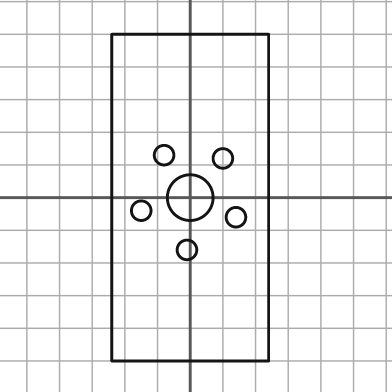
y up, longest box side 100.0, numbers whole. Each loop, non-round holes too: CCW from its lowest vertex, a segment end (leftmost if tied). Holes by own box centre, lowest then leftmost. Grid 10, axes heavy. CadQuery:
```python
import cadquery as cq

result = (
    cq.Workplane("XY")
    .moveTo(-24.0, -50.0)
    .lineTo(24.0, -50.0)
    .lineTo(24.0, 50.0)
    .lineTo(-24.0, 50.0)
    .close()
    .moveTo(-1.0, -16.0)
    .circle(3.0)
    .moveTo(14.0, -6.0)
    .circle(3.0)
    .moveTo(-15.0, -4.0)
    .circle(3.0)
    .moveTo(0.0, 0.0)
    .circle(7.0)
    .moveTo(10.0, 12.0)
    .circle(3.0)
    .moveTo(-8.0, 13.0)
    .circle(3.0)
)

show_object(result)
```